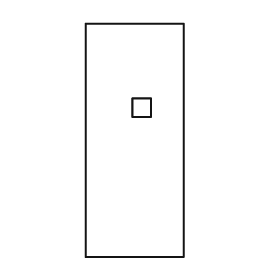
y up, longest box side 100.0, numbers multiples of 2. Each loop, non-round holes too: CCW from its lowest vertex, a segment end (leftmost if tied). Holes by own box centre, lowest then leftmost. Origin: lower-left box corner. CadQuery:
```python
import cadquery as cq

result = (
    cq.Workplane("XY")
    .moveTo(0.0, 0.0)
    .lineTo(42.0, 0.0)
    .lineTo(42.0, 100.0)
    .lineTo(0.0, 100.0)
    .close()
    .moveTo(20.0, 60.0)
    .lineTo(28.0, 60.0)
    .lineTo(28.0, 68.0)
    .lineTo(20.0, 68.0)
    .close()
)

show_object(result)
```